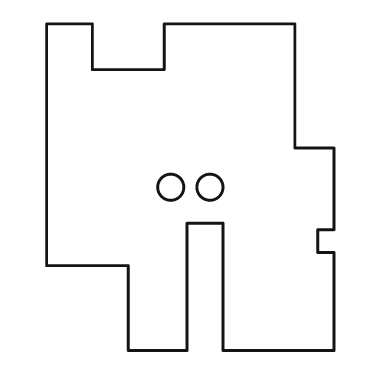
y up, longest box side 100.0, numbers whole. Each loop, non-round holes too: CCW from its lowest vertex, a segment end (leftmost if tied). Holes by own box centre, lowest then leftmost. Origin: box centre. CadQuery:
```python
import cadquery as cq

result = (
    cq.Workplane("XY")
    .moveTo(-19.0, -50.0)
    .lineTo(-1.0, -50.0)
    .lineTo(-1.0, -11.0)
    .lineTo(10.0, -11.0)
    .lineTo(10.0, -50.0)
    .lineTo(44.0, -50.0)
    .lineTo(44.0, -20.0)
    .lineTo(39.0, -20.0)
    .lineTo(39.0, -13.0)
    .lineTo(44.0, -13.0)
    .lineTo(44.0, 12.0)
    .lineTo(32.0, 12.0)
    .lineTo(32.0, 50.0)
    .lineTo(-8.0, 50.0)
    .lineTo(-8.0, 36.0)
    .lineTo(-30.0, 36.0)
    .lineTo(-30.0, 50.0)
    .lineTo(-44.0, 50.0)
    .lineTo(-44.0, -24.0)
    .lineTo(-19.0, -24.0)
    .close()
    .moveTo(-6.0, 0.0)
    .circle(4.0)
    .moveTo(6.0, 0.0)
    .circle(4.0)
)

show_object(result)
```